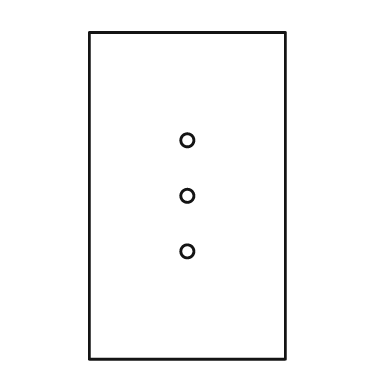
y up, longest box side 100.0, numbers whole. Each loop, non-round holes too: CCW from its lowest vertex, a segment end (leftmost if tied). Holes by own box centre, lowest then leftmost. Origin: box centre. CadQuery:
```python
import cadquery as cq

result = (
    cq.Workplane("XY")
    .moveTo(-30.0, -50.0)
    .lineTo(30.0, -50.0)
    .lineTo(30.0, 50.0)
    .lineTo(-30.0, 50.0)
    .close()
    .moveTo(0.0, -17.0)
    .circle(2.0)
    .moveTo(0.0, 0.0)
    .circle(2.0)
    .moveTo(0.0, 17.0)
    .circle(2.0)
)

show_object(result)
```